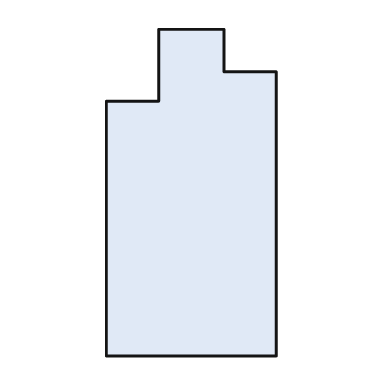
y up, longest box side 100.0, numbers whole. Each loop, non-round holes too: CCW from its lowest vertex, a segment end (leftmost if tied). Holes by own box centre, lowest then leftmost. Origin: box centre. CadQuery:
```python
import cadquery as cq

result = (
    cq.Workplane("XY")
    .moveTo(-26.0, -50.0)
    .lineTo(26.0, -50.0)
    .lineTo(26.0, 37.0)
    .lineTo(10.0, 37.0)
    .lineTo(10.0, 50.0)
    .lineTo(-10.0, 50.0)
    .lineTo(-10.0, 28.0)
    .lineTo(-26.0, 28.0)
    .close()
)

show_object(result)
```